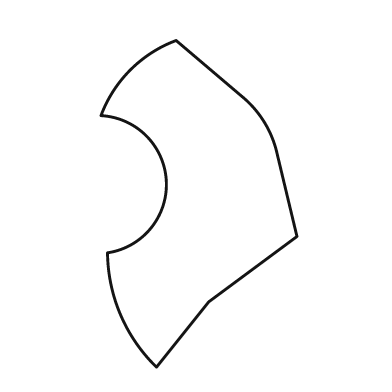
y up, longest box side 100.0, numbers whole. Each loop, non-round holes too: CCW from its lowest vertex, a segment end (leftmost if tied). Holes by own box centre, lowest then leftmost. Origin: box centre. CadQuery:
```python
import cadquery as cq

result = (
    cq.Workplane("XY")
    .moveTo(-13.0, -50.0)
    .lineTo(3.0, -30.0)
    .lineTo(30.0, -10.0)
    .lineTo(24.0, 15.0)
    .threePointArc((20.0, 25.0), (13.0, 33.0))
    .lineTo(-7.0, 50.0)
    .threePointArc((-21.0, 41.0), (-30.0, 27.0))
    .threePointArc((-10.0, 7.0), (-28.0, -15.0))
    .threePointArc((-24.0, -34.0), (-13.0, -50.0))
    .close()
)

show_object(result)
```